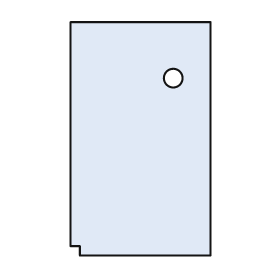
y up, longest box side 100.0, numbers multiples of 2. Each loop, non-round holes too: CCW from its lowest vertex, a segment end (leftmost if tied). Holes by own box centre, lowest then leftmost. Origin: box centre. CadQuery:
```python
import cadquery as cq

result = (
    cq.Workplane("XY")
    .moveTo(-26.0, -50.0)
    .lineTo(30.0, -50.0)
    .lineTo(30.0, 50.0)
    .lineTo(-30.0, 50.0)
    .lineTo(-30.0, -46.0)
    .lineTo(-26.0, -46.0)
    .close()
    .moveTo(14.0, 26.0)
    .circle(4.0)
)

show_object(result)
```